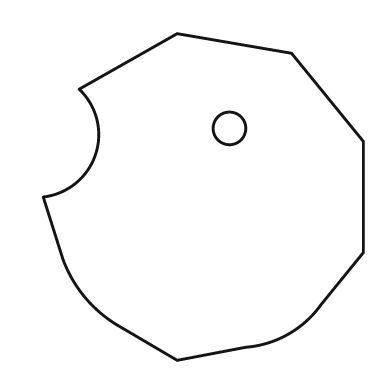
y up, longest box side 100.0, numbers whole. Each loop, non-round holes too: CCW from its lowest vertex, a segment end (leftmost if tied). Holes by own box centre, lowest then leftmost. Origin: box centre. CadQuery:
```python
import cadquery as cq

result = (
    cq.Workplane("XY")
    .moveTo(-8.0, -50.0)
    .lineTo(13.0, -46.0)
    .threePointArc((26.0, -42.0), (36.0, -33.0))
    .lineTo(49.0, -17.0)
    .lineTo(49.0, 17.0)
    .lineTo(27.0, 44.0)
    .lineTo(-8.0, 50.0)
    .lineTo(-38.0, 33.0)
    .threePointArc((-33.0, 13.0), (-49.0, 0.0))
    .lineTo(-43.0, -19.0)
    .threePointArc((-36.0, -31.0), (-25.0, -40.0))
    .close()
    .moveTo(8.0, 21.0)
    .circle(5.0)
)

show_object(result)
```